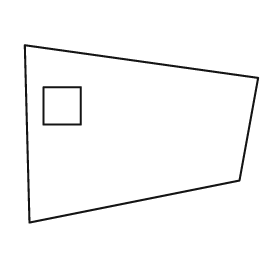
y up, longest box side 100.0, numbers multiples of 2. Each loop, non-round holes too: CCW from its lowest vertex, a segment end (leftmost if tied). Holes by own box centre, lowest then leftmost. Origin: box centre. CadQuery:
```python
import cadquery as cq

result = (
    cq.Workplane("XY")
    .moveTo(-48.0, -38.0)
    .lineTo(42.0, -20.0)
    .lineTo(50.0, 24.0)
    .lineTo(-50.0, 38.0)
    .close()
    .moveTo(-42.0, 4.0)
    .lineTo(-26.0, 4.0)
    .lineTo(-26.0, 20.0)
    .lineTo(-42.0, 20.0)
    .close()
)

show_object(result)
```